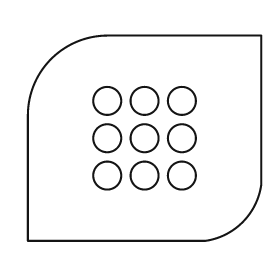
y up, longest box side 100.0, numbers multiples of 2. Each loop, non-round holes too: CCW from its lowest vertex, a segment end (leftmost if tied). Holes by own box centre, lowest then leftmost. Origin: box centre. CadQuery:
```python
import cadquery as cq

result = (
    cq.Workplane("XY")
    .moveTo(-50.0, -44.0)
    .lineTo(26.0, -44.0)
    .threePointArc((42.0, -36.0), (50.0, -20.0))
    .lineTo(50.0, 44.0)
    .lineTo(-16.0, 44.0)
    .threePointArc((-40.0, 34.0), (-50.0, 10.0))
    .close()
    .moveTo(-16.0, -16.0)
    .circle(6.0)
    .moveTo(0.0, -16.0)
    .circle(6.0)
    .moveTo(16.0, -16.0)
    .circle(6.0)
    .moveTo(-16.0, 0.0)
    .circle(6.0)
    .moveTo(0.0, 0.0)
    .circle(6.0)
    .moveTo(16.0, 0.0)
    .circle(6.0)
    .moveTo(-16.0, 16.0)
    .circle(6.0)
    .moveTo(0.0, 16.0)
    .circle(6.0)
    .moveTo(16.0, 16.0)
    .circle(6.0)
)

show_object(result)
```